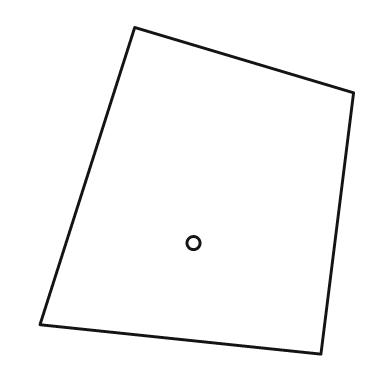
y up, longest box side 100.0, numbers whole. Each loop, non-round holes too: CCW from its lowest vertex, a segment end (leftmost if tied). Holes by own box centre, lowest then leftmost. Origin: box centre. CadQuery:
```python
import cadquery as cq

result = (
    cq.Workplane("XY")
    .moveTo(38.0, -50.0)
    .lineTo(48.0, 30.0)
    .lineTo(-19.0, 50.0)
    .lineTo(-48.0, -41.0)
    .close()
    .moveTo(-1.0, -16.0)
    .circle(2.0)
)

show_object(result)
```